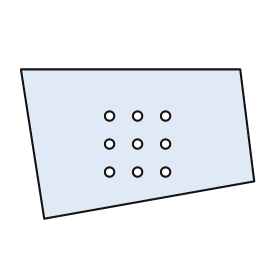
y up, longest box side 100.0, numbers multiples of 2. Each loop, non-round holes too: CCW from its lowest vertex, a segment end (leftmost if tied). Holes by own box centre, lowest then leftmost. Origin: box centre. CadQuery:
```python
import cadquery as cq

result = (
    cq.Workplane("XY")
    .moveTo(-40.0, -32.0)
    .lineTo(50.0, -16.0)
    .lineTo(44.0, 32.0)
    .lineTo(-50.0, 32.0)
    .close()
    .moveTo(-12.0, -12.0)
    .circle(2.0)
    .moveTo(0.0, -12.0)
    .circle(2.0)
    .moveTo(12.0, -12.0)
    .circle(2.0)
    .moveTo(-12.0, 0.0)
    .circle(2.0)
    .moveTo(0.0, 0.0)
    .circle(2.0)
    .moveTo(12.0, 0.0)
    .circle(2.0)
    .moveTo(-12.0, 12.0)
    .circle(2.0)
    .moveTo(0.0, 12.0)
    .circle(2.0)
    .moveTo(12.0, 12.0)
    .circle(2.0)
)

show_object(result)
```